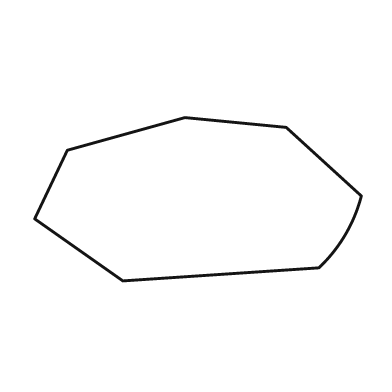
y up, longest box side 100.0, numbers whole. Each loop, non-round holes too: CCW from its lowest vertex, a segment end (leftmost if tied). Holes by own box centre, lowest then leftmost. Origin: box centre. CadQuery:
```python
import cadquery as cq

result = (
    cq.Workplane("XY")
    .moveTo(-23.0, -25.0)
    .lineTo(37.0, -21.0)
    .threePointArc((45.0, -11.0), (50.0, 1.0))
    .lineTo(27.0, 22.0)
    .lineTo(-4.0, 25.0)
    .lineTo(-40.0, 15.0)
    .lineTo(-50.0, -6.0)
    .close()
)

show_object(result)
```